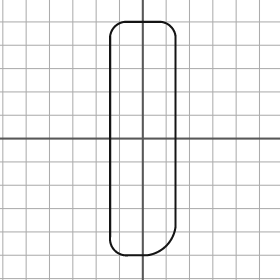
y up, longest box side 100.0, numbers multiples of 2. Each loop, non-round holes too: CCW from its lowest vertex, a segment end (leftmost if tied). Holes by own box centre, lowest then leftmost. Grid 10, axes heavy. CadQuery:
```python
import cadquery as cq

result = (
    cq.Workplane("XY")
    .moveTo(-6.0, -50.0)
    .lineTo(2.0, -50.0)
    .threePointArc((10.0, -46.0), (14.0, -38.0))
    .lineTo(14.0, 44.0)
    .threePointArc((12.0, 48.0), (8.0, 50.0))
    .lineTo(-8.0, 50.0)
    .threePointArc((-12.0, 48.0), (-14.0, 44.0))
    .lineTo(-14.0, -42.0)
    .threePointArc((-12.0, -48.0), (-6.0, -50.0))
    .close()
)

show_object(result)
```